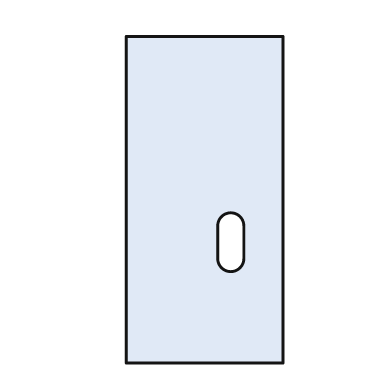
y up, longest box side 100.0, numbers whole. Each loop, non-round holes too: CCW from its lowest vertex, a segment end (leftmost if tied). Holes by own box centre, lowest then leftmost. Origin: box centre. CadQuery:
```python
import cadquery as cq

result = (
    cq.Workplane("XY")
    .moveTo(-24.0, -50.0)
    .lineTo(24.0, -50.0)
    .lineTo(24.0, 50.0)
    .lineTo(-24.0, 50.0)
    .close()
    .moveTo(4.0, -18.0)
    .threePointArc((8.0, -22.0), (12.0, -18.0))
    .lineTo(12.0, -8.0)
    .threePointArc((8.0, -4.0), (4.0, -8.0))
    .close()
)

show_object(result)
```